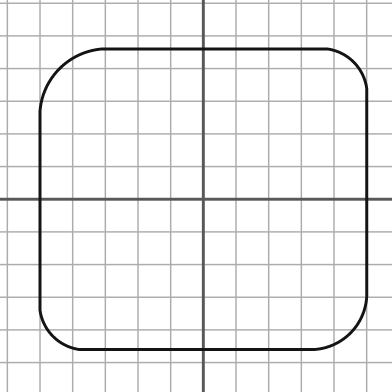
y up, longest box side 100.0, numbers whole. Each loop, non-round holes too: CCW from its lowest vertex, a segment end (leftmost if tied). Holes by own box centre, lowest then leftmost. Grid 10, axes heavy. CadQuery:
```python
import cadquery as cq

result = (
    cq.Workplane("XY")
    .moveTo(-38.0, -46.0)
    .lineTo(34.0, -46.0)
    .threePointArc((45.0, -41.0), (50.0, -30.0))
    .lineTo(50.0, 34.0)
    .threePointArc((46.0, 42.0), (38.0, 46.0))
    .lineTo(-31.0, 46.0)
    .threePointArc((-44.0, 40.0), (-50.0, 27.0))
    .lineTo(-50.0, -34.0)
    .threePointArc((-46.0, -42.0), (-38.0, -46.0))
    .close()
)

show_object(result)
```